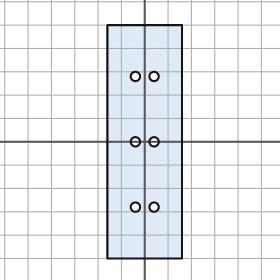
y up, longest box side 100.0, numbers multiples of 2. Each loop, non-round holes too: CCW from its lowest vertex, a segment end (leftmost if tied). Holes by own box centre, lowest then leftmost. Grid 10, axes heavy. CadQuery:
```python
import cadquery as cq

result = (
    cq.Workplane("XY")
    .moveTo(-16.0, -50.0)
    .lineTo(16.0, -50.0)
    .lineTo(16.0, 50.0)
    .lineTo(-16.0, 50.0)
    .close()
    .moveTo(-4.0, -28.0)
    .circle(2.0)
    .moveTo(4.0, -28.0)
    .circle(2.0)
    .moveTo(-4.0, 0.0)
    .circle(2.0)
    .moveTo(4.0, 0.0)
    .circle(2.0)
    .moveTo(-4.0, 28.0)
    .circle(2.0)
    .moveTo(4.0, 28.0)
    .circle(2.0)
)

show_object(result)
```